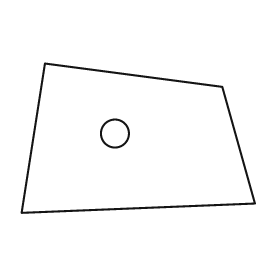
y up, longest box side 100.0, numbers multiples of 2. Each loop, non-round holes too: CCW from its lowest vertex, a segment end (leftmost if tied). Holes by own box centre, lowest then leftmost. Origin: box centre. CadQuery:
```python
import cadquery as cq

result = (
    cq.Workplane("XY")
    .moveTo(-50.0, -32.0)
    .lineTo(50.0, -28.0)
    .lineTo(36.0, 22.0)
    .lineTo(-40.0, 32.0)
    .close()
    .moveTo(-10.0, 2.0)
    .circle(6.0)
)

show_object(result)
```